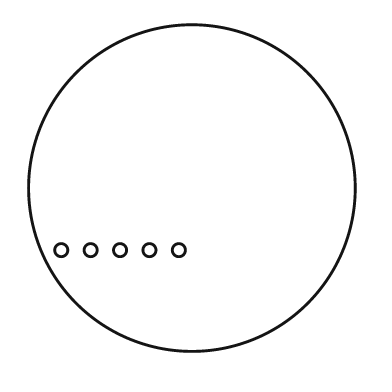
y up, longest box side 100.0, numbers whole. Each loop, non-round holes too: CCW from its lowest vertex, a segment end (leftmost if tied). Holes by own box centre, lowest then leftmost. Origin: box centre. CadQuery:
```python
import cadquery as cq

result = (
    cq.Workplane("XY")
    .moveTo(0.0, 0.0)
    .circle(50.0)
    .moveTo(-40.0, -19.0)
    .circle(2.0)
    .moveTo(-31.0, -19.0)
    .circle(2.0)
    .moveTo(-22.0, -19.0)
    .circle(2.0)
    .moveTo(-13.0, -19.0)
    .circle(2.0)
    .moveTo(-4.0, -19.0)
    .circle(2.0)
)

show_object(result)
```